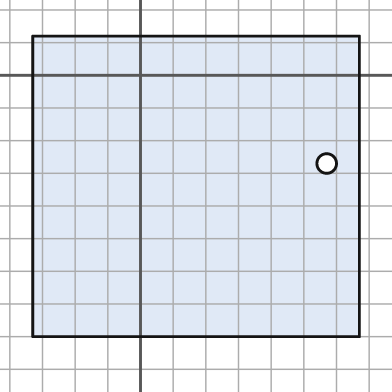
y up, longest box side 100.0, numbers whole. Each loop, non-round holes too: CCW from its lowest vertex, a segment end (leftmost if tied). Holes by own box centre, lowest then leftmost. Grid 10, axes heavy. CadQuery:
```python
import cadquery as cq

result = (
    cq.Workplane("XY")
    .moveTo(-33.0, -80.0)
    .lineTo(67.0, -80.0)
    .lineTo(67.0, 12.0)
    .lineTo(-33.0, 12.0)
    .close()
    .moveTo(57.0, -27.0)
    .circle(3.0)
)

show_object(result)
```